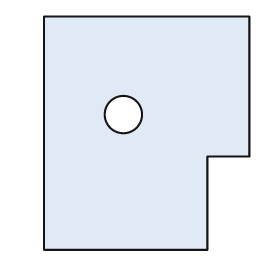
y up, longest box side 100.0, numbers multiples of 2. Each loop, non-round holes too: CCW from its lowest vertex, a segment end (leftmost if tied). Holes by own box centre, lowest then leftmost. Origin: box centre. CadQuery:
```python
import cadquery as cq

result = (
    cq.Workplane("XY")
    .moveTo(-44.0, -50.0)
    .lineTo(26.0, -50.0)
    .lineTo(26.0, -10.0)
    .lineTo(44.0, -10.0)
    .lineTo(44.0, 50.0)
    .lineTo(-44.0, 50.0)
    .close()
    .moveTo(-10.0, 8.0)
    .circle(8.0)
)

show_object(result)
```